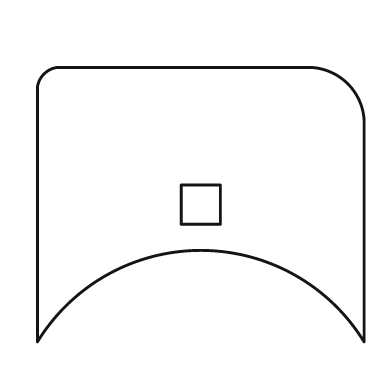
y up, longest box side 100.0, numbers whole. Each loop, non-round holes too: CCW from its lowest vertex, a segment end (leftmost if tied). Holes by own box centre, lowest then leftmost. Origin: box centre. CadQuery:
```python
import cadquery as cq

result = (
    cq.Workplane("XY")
    .moveTo(-50.0, -42.0)
    .threePointArc((0.0, -14.0), (50.0, -42.0))
    .lineTo(50.0, 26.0)
    .threePointArc((45.0, 37.0), (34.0, 42.0))
    .lineTo(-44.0, 42.0)
    .threePointArc((-48.0, 40.0), (-50.0, 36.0))
    .close()
    .moveTo(-6.0, -6.0)
    .lineTo(6.0, -6.0)
    .lineTo(6.0, 6.0)
    .lineTo(-6.0, 6.0)
    .close()
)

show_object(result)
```